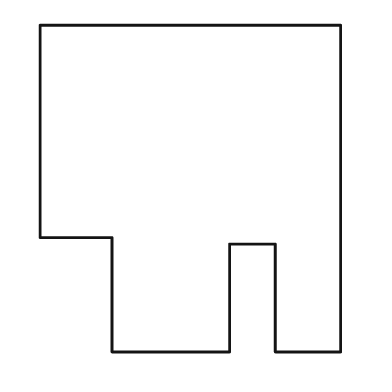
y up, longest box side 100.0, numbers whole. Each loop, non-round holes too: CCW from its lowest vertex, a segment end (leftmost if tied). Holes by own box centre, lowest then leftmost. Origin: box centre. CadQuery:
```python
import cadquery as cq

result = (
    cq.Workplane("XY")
    .moveTo(-24.0, -50.0)
    .lineTo(12.0, -50.0)
    .lineTo(12.0, -17.0)
    .lineTo(26.0, -17.0)
    .lineTo(26.0, -50.0)
    .lineTo(46.0, -50.0)
    .lineTo(46.0, 50.0)
    .lineTo(-46.0, 50.0)
    .lineTo(-46.0, -15.0)
    .lineTo(-24.0, -15.0)
    .close()
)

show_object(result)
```